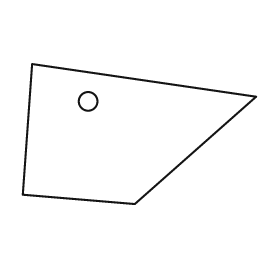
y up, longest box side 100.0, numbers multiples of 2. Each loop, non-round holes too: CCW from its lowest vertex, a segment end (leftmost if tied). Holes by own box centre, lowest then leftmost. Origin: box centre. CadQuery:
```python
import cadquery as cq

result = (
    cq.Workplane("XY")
    .moveTo(-2.0, -30.0)
    .lineTo(50.0, 16.0)
    .lineTo(-46.0, 30.0)
    .lineTo(-50.0, -26.0)
    .close()
    .moveTo(-22.0, 14.0)
    .circle(4.0)
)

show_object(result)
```